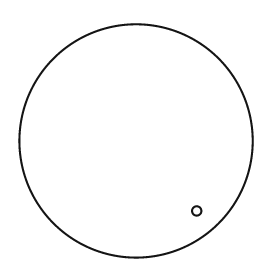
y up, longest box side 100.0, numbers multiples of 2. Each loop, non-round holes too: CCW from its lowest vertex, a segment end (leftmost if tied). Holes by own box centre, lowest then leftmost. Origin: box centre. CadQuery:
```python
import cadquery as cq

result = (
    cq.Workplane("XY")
    .moveTo(0.0, 0.0)
    .circle(50.0)
    .moveTo(26.0, -30.0)
    .circle(2.0)
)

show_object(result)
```